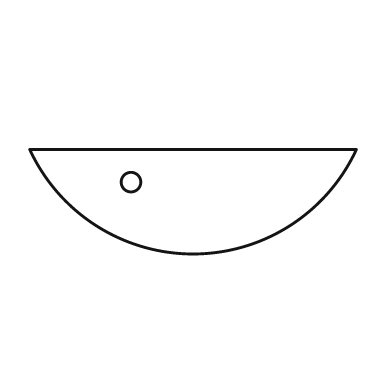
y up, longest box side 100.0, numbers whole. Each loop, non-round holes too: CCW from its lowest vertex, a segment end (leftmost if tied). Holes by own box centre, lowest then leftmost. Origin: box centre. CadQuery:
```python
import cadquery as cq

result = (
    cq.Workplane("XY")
    .moveTo(-50.0, 16.0)
    .threePointArc((0.0, -16.0), (50.0, 16.0))
    .close()
    .moveTo(-19.0, 6.0)
    .circle(3.0)
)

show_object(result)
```